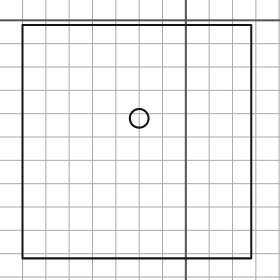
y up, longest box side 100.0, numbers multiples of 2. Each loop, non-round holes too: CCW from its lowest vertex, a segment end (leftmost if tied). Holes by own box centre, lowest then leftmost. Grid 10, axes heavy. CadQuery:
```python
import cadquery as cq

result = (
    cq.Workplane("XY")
    .moveTo(-70.0, -102.0)
    .lineTo(28.0, -102.0)
    .lineTo(28.0, -2.0)
    .lineTo(-70.0, -2.0)
    .close()
    .moveTo(-20.0, -42.0)
    .circle(4.0)
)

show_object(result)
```